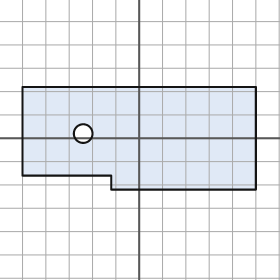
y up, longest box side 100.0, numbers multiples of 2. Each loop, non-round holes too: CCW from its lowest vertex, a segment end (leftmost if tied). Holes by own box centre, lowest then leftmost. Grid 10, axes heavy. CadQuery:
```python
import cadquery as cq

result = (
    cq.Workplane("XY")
    .moveTo(-12.0, -22.0)
    .lineTo(50.0, -22.0)
    .lineTo(50.0, 22.0)
    .lineTo(-50.0, 22.0)
    .lineTo(-50.0, -16.0)
    .lineTo(-12.0, -16.0)
    .close()
    .moveTo(-24.0, 2.0)
    .circle(4.0)
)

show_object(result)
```